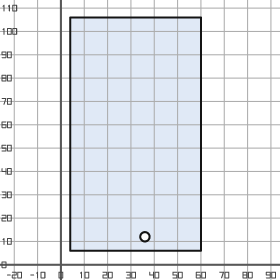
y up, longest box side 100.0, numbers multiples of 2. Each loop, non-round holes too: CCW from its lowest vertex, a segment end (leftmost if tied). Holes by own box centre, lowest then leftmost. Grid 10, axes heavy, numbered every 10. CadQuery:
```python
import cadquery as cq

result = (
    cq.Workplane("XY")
    .moveTo(4.0, 6.0)
    .lineTo(60.0, 6.0)
    .lineTo(60.0, 106.0)
    .lineTo(4.0, 106.0)
    .close()
    .moveTo(36.0, 12.0)
    .circle(2.0)
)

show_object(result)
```